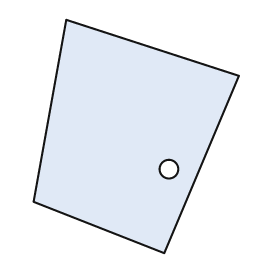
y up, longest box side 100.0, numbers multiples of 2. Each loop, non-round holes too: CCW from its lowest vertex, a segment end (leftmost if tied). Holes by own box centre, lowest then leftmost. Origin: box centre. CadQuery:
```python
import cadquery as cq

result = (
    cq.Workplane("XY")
    .moveTo(12.0, -50.0)
    .lineTo(44.0, 26.0)
    .lineTo(-30.0, 50.0)
    .lineTo(-44.0, -28.0)
    .close()
    .moveTo(14.0, -14.0)
    .circle(4.0)
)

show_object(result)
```